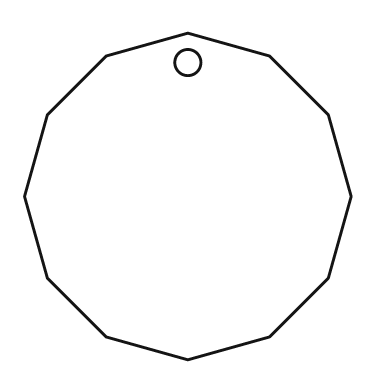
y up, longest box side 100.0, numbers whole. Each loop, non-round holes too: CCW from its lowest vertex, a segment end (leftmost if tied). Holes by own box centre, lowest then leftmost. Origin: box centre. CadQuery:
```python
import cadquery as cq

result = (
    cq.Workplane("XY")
    .moveTo(0.0, -50.0)
    .lineTo(25.0, -43.0)
    .lineTo(43.0, -25.0)
    .lineTo(50.0, 0.0)
    .lineTo(43.0, 25.0)
    .lineTo(25.0, 43.0)
    .lineTo(0.0, 50.0)
    .lineTo(-25.0, 43.0)
    .lineTo(-43.0, 25.0)
    .lineTo(-50.0, 0.0)
    .lineTo(-43.0, -25.0)
    .lineTo(-25.0, -43.0)
    .close()
    .moveTo(0.0, 41.0)
    .circle(4.0)
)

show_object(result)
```